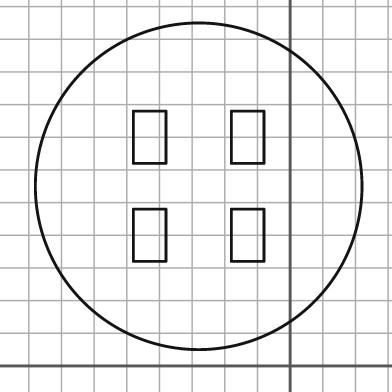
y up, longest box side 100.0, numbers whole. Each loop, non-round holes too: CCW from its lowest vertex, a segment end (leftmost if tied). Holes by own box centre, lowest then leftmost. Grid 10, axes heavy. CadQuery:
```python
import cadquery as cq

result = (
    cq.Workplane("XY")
    .moveTo(-28.0, 55.0)
    .circle(50.0)
    .moveTo(-48.0, 32.0)
    .lineTo(-38.0, 32.0)
    .lineTo(-38.0, 48.0)
    .lineTo(-48.0, 48.0)
    .close()
    .moveTo(-18.0, 32.0)
    .lineTo(-8.0, 32.0)
    .lineTo(-8.0, 48.0)
    .lineTo(-18.0, 48.0)
    .close()
    .moveTo(-48.0, 62.0)
    .lineTo(-38.0, 62.0)
    .lineTo(-38.0, 78.0)
    .lineTo(-48.0, 78.0)
    .close()
    .moveTo(-18.0, 62.0)
    .lineTo(-8.0, 62.0)
    .lineTo(-8.0, 78.0)
    .lineTo(-18.0, 78.0)
    .close()
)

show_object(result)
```